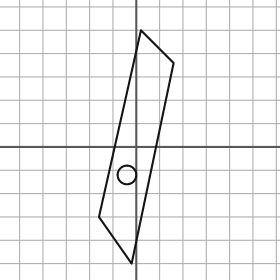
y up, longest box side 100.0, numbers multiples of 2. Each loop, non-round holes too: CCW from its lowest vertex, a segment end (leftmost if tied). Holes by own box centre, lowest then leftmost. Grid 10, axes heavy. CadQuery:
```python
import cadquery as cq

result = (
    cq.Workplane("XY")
    .moveTo(-2.0, -50.0)
    .lineTo(16.0, 36.0)
    .lineTo(2.0, 50.0)
    .lineTo(-16.0, -30.0)
    .close()
    .moveTo(-4.0, -12.0)
    .circle(4.0)
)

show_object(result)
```